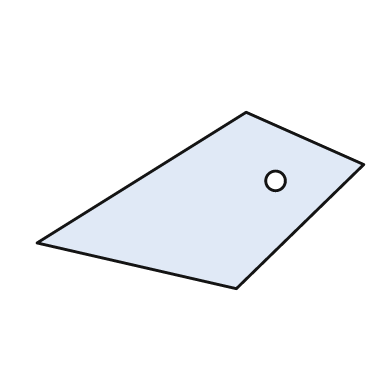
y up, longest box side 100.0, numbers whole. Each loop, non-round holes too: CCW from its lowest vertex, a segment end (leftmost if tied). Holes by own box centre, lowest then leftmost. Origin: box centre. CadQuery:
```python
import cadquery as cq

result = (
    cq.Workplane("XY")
    .moveTo(11.0, -27.0)
    .lineTo(50.0, 11.0)
    .lineTo(14.0, 27.0)
    .lineTo(-50.0, -13.0)
    .close()
    .moveTo(23.0, 6.0)
    .circle(3.0)
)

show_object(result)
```